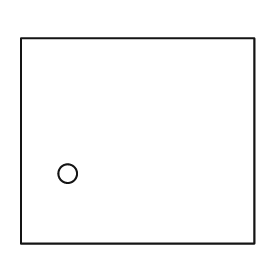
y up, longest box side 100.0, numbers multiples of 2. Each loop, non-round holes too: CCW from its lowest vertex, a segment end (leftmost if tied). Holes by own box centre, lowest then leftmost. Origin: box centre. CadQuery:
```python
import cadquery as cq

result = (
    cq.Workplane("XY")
    .moveTo(-50.0, -44.0)
    .lineTo(50.0, -44.0)
    .lineTo(50.0, 44.0)
    .lineTo(-50.0, 44.0)
    .close()
    .moveTo(-30.0, -14.0)
    .circle(4.0)
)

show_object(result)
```